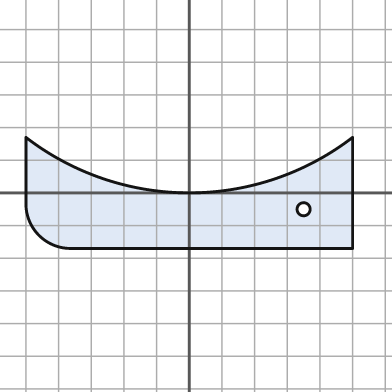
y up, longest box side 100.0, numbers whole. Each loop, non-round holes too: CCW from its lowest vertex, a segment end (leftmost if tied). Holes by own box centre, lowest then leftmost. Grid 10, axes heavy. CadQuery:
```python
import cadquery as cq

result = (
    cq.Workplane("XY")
    .moveTo(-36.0, -17.0)
    .lineTo(50.0, -17.0)
    .lineTo(50.0, 17.0)
    .threePointArc((0.0, 0.0), (-50.0, 17.0))
    .lineTo(-50.0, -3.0)
    .threePointArc((-46.0, -13.0), (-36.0, -17.0))
    .close()
    .moveTo(35.0, -5.0)
    .circle(2.0)
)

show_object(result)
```